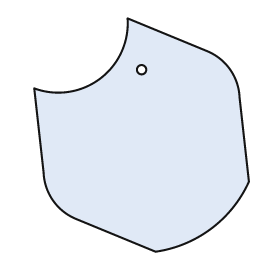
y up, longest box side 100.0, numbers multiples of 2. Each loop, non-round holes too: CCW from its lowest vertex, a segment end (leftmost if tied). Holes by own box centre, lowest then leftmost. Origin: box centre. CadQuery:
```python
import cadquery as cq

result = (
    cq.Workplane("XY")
    .moveTo(6.0, -50.0)
    .threePointArc((30.0, -40.0), (46.0, -20.0))
    .lineTo(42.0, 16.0)
    .threePointArc((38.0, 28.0), (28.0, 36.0))
    .lineTo(-6.0, 50.0)
    .threePointArc((-18.0, 24.0), (-46.0, 20.0))
    .lineTo(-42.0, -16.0)
    .threePointArc((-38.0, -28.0), (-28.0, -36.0))
    .close()
    .moveTo(0.0, 28.0)
    .circle(2.0)
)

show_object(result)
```